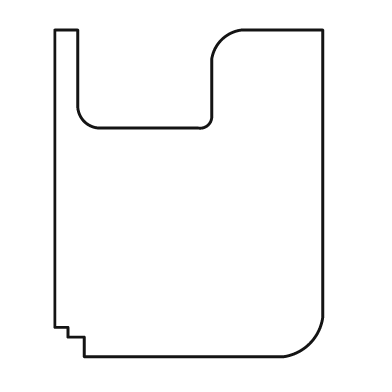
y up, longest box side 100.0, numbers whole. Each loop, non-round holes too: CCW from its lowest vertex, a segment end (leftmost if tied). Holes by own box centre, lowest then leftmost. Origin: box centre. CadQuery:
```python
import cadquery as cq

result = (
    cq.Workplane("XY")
    .moveTo(-32.0, -50.0)
    .lineTo(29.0, -50.0)
    .threePointArc((37.0, -46.0), (41.0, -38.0))
    .lineTo(41.0, 50.0)
    .lineTo(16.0, 50.0)
    .threePointArc((10.0, 47.0), (7.0, 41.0))
    .lineTo(7.0, 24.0)
    .threePointArc((6.0, 21.0), (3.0, 20.0))
    .lineTo(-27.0, 20.0)
    .threePointArc((-32.0, 22.0), (-34.0, 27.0))
    .lineTo(-34.0, 50.0)
    .lineTo(-41.0, 50.0)
    .lineTo(-41.0, -41.0)
    .lineTo(-37.0, -41.0)
    .lineTo(-37.0, -44.0)
    .lineTo(-32.0, -44.0)
    .close()
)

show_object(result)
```